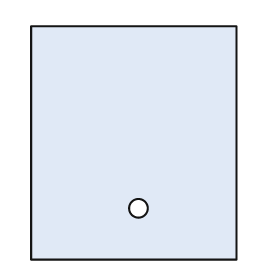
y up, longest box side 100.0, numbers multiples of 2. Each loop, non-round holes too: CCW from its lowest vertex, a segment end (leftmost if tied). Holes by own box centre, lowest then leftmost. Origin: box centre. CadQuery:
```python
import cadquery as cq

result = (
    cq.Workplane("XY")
    .moveTo(-44.0, -50.0)
    .lineTo(44.0, -50.0)
    .lineTo(44.0, 50.0)
    .lineTo(-44.0, 50.0)
    .close()
    .moveTo(2.0, -28.0)
    .circle(4.0)
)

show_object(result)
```